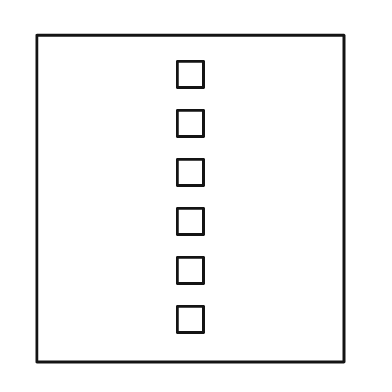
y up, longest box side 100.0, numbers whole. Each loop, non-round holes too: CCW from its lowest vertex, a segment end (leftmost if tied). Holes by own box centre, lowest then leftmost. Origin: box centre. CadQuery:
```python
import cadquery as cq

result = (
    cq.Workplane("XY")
    .moveTo(-47.0, -50.0)
    .lineTo(47.0, -50.0)
    .lineTo(47.0, 50.0)
    .lineTo(-47.0, 50.0)
    .close()
    .moveTo(-4.0, -41.0)
    .lineTo(4.0, -41.0)
    .lineTo(4.0, -33.0)
    .lineTo(-4.0, -33.0)
    .close()
    .moveTo(-4.0, -26.0)
    .lineTo(4.0, -26.0)
    .lineTo(4.0, -18.0)
    .lineTo(-4.0, -18.0)
    .close()
    .moveTo(-4.0, -11.0)
    .lineTo(4.0, -11.0)
    .lineTo(4.0, -3.0)
    .lineTo(-4.0, -3.0)
    .close()
    .moveTo(-4.0, 4.0)
    .lineTo(4.0, 4.0)
    .lineTo(4.0, 12.0)
    .lineTo(-4.0, 12.0)
    .close()
    .moveTo(-4.0, 19.0)
    .lineTo(4.0, 19.0)
    .lineTo(4.0, 27.0)
    .lineTo(-4.0, 27.0)
    .close()
    .moveTo(-4.0, 34.0)
    .lineTo(4.0, 34.0)
    .lineTo(4.0, 42.0)
    .lineTo(-4.0, 42.0)
    .close()
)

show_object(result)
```